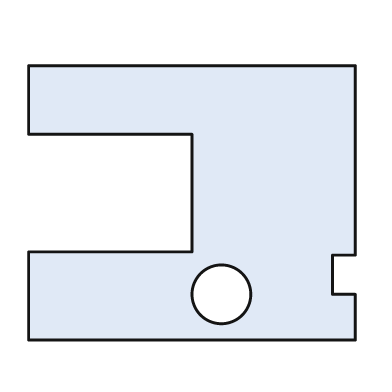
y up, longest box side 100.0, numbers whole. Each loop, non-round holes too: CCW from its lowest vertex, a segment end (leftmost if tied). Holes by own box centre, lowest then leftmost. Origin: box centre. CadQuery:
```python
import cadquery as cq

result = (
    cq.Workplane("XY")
    .moveTo(-50.0, -42.0)
    .lineTo(50.0, -42.0)
    .lineTo(50.0, -28.0)
    .lineTo(43.0, -28.0)
    .lineTo(43.0, -16.0)
    .lineTo(50.0, -16.0)
    .lineTo(50.0, 42.0)
    .lineTo(-50.0, 42.0)
    .lineTo(-50.0, 21.0)
    .lineTo(0.0, 21.0)
    .lineTo(0.0, -15.0)
    .lineTo(-50.0, -15.0)
    .close()
    .moveTo(9.0, -28.0)
    .circle(9.0)
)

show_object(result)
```